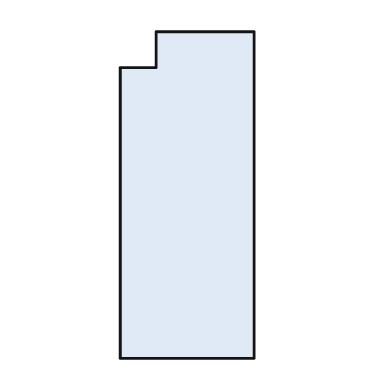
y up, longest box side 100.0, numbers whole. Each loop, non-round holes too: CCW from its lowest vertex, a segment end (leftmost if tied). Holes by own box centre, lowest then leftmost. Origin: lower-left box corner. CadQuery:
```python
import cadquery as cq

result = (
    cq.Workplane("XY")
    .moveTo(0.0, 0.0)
    .lineTo(41.0, 0.0)
    .lineTo(41.0, 100.0)
    .lineTo(11.0, 100.0)
    .lineTo(11.0, 89.0)
    .lineTo(0.0, 89.0)
    .close()
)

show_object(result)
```